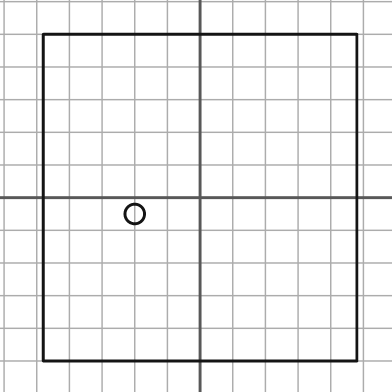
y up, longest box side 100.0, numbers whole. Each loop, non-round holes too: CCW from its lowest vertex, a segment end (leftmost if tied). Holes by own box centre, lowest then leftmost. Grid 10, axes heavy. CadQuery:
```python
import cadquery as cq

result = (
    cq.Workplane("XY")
    .moveTo(-48.0, -50.0)
    .lineTo(48.0, -50.0)
    .lineTo(48.0, 50.0)
    .lineTo(-48.0, 50.0)
    .close()
    .moveTo(-20.0, -5.0)
    .circle(3.0)
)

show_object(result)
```